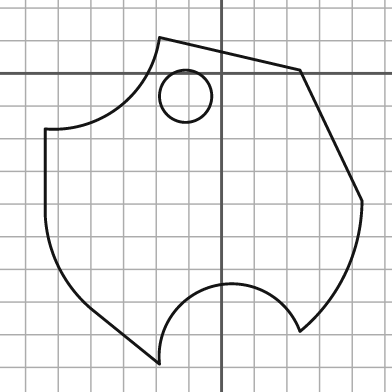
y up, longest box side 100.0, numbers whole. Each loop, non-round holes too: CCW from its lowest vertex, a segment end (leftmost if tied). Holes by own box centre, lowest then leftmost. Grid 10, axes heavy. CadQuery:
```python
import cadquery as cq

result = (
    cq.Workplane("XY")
    .moveTo(-19.0, -89.0)
    .threePointArc((-2.0, -65.0), (24.0, -79.0))
    .threePointArc((38.0, -61.0), (43.0, -39.0))
    .lineTo(24.0, 1.0)
    .lineTo(-19.0, 11.0)
    .threePointArc((-31.0, -10.0), (-54.0, -17.0))
    .lineTo(-54.0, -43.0)
    .threePointArc((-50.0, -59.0), (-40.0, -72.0))
    .close()
    .moveTo(-11.0, -7.0)
    .circle(8.0)
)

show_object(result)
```